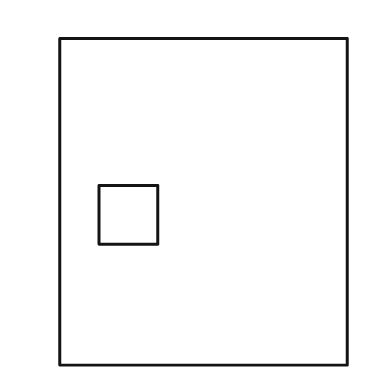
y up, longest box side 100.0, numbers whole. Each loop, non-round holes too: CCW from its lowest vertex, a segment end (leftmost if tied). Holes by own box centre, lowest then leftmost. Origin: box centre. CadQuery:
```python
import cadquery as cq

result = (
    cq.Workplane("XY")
    .moveTo(-44.0, -50.0)
    .lineTo(44.0, -50.0)
    .lineTo(44.0, 50.0)
    .lineTo(-44.0, 50.0)
    .close()
    .moveTo(-32.0, -13.0)
    .lineTo(-14.0, -13.0)
    .lineTo(-14.0, 5.0)
    .lineTo(-32.0, 5.0)
    .close()
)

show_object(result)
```